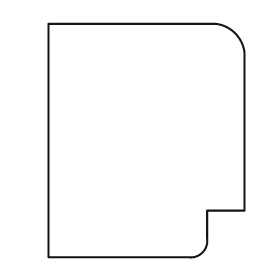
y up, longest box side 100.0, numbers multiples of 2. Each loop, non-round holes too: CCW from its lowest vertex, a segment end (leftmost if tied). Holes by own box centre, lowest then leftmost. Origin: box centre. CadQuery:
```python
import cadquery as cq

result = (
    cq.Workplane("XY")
    .moveTo(-42.0, -50.0)
    .lineTo(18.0, -50.0)
    .threePointArc((24.0, -48.0), (26.0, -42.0))
    .lineTo(26.0, -30.0)
    .lineTo(42.0, -30.0)
    .lineTo(42.0, 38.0)
    .threePointArc((38.0, 46.0), (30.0, 50.0))
    .lineTo(-42.0, 50.0)
    .close()
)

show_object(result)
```